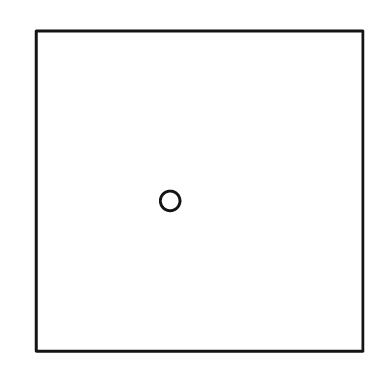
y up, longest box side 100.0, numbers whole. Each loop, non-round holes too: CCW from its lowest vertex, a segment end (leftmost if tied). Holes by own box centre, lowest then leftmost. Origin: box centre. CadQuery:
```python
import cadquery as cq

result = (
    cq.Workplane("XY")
    .moveTo(-50.0, -49.0)
    .lineTo(50.0, -49.0)
    .lineTo(50.0, 49.0)
    .lineTo(-50.0, 49.0)
    .close()
    .moveTo(-9.0, -3.0)
    .circle(3.0)
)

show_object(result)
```